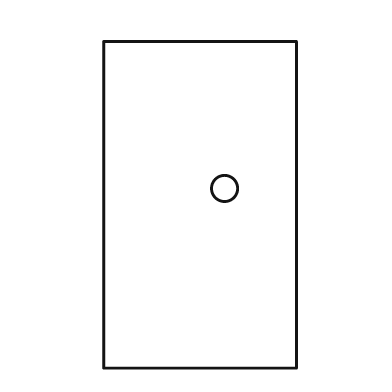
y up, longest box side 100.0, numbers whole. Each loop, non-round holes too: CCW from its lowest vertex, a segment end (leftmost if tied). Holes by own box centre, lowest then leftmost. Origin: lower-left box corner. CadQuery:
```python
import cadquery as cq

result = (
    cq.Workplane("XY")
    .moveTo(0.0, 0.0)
    .lineTo(59.0, 0.0)
    .lineTo(59.0, 100.0)
    .lineTo(0.0, 100.0)
    .close()
    .moveTo(37.0, 55.0)
    .circle(4.0)
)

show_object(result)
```